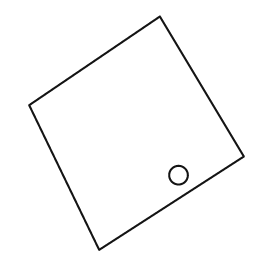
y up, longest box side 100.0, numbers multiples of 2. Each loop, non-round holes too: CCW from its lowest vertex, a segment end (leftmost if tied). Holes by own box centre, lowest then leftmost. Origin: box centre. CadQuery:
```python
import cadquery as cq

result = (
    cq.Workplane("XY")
    .moveTo(-16.0, -50.0)
    .lineTo(46.0, -10.0)
    .lineTo(10.0, 50.0)
    .lineTo(-46.0, 12.0)
    .close()
    .moveTo(18.0, -18.0)
    .circle(4.0)
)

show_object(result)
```